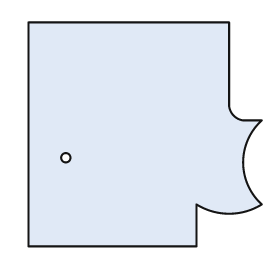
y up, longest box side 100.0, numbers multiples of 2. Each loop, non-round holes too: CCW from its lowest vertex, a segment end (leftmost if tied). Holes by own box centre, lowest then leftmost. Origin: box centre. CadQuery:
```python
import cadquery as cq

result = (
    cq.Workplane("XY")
    .moveTo(-50.0, -48.0)
    .lineTo(22.0, -48.0)
    .lineTo(22.0, -30.0)
    .threePointArc((36.0, -34.0), (50.0, -30.0))
    .threePointArc((42.0, -12.0), (50.0, 6.0))
    .lineTo(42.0, 6.0)
    .threePointArc((38.0, 8.0), (36.0, 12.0))
    .lineTo(36.0, 48.0)
    .lineTo(-50.0, 48.0)
    .close()
    .moveTo(-34.0, -10.0)
    .circle(2.0)
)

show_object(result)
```